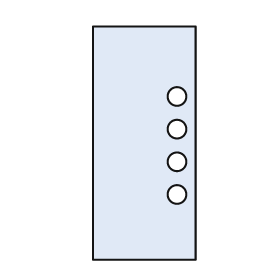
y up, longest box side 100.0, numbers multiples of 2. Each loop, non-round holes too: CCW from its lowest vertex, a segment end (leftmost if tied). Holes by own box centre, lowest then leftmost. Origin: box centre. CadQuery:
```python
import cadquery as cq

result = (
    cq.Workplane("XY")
    .moveTo(-22.0, -50.0)
    .lineTo(22.0, -50.0)
    .lineTo(22.0, 50.0)
    .lineTo(-22.0, 50.0)
    .close()
    .moveTo(14.0, -22.0)
    .circle(4.0)
    .moveTo(14.0, -8.0)
    .circle(4.0)
    .moveTo(14.0, 6.0)
    .circle(4.0)
    .moveTo(14.0, 20.0)
    .circle(4.0)
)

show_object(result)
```